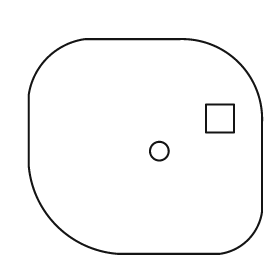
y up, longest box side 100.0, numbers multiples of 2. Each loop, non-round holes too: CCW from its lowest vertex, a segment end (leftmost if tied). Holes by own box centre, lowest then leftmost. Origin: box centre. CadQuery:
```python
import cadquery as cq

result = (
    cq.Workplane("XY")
    .moveTo(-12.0, -46.0)
    .lineTo(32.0, -46.0)
    .threePointArc((44.0, -40.0), (50.0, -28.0))
    .lineTo(50.0, 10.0)
    .threePointArc((40.0, 36.0), (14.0, 46.0))
    .lineTo(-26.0, 46.0)
    .threePointArc((-42.0, 38.0), (-50.0, 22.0))
    .lineTo(-50.0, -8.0)
    .threePointArc((-38.0, -34.0), (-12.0, -46.0))
    .close()
    .moveTo(6.0, -2.0)
    .circle(4.0)
    .moveTo(26.0, 6.0)
    .lineTo(38.0, 6.0)
    .lineTo(38.0, 18.0)
    .lineTo(26.0, 18.0)
    .close()
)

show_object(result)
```